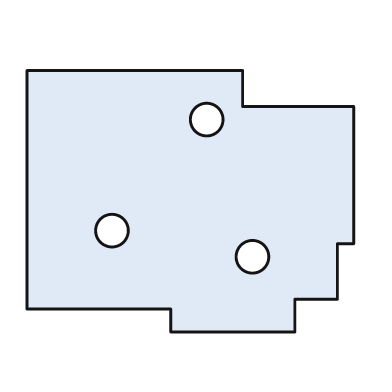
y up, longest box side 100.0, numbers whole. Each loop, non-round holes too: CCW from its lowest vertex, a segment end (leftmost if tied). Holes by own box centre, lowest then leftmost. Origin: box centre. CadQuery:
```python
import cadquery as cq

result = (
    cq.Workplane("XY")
    .moveTo(-6.0, -40.0)
    .lineTo(32.0, -40.0)
    .lineTo(32.0, -30.0)
    .lineTo(45.0, -30.0)
    .lineTo(45.0, -13.0)
    .lineTo(50.0, -13.0)
    .lineTo(50.0, 29.0)
    .lineTo(16.0, 29.0)
    .lineTo(16.0, 40.0)
    .lineTo(-50.0, 40.0)
    .lineTo(-50.0, -33.0)
    .lineTo(-6.0, -33.0)
    .close()
    .moveTo(19.0, -17.0)
    .circle(5.0)
    .moveTo(-24.0, -9.0)
    .circle(5.0)
    .moveTo(5.0, 25.0)
    .circle(5.0)
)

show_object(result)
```